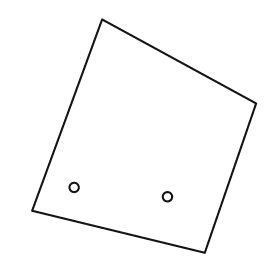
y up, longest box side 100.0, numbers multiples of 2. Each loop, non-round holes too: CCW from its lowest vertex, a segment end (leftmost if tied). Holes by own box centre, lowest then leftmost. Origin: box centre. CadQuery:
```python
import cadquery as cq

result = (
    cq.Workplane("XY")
    .moveTo(26.0, -50.0)
    .lineTo(48.0, 14.0)
    .lineTo(-18.0, 50.0)
    .lineTo(-48.0, -32.0)
    .close()
    .moveTo(10.0, -26.0)
    .circle(2.0)
    .moveTo(-30.0, -22.0)
    .circle(2.0)
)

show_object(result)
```